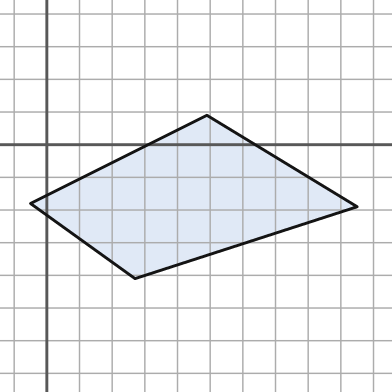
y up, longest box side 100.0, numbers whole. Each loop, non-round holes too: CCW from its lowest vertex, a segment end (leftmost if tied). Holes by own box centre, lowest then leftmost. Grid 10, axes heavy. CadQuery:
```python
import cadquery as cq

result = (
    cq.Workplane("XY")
    .moveTo(27.0, -41.0)
    .lineTo(95.0, -19.0)
    .lineTo(49.0, 9.0)
    .lineTo(-5.0, -18.0)
    .close()
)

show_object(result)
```